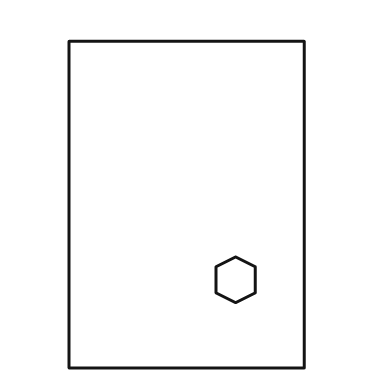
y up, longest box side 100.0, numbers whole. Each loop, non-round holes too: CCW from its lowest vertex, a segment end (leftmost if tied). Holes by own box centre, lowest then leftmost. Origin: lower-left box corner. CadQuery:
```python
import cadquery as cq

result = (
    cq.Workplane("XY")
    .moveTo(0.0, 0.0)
    .lineTo(72.0, 0.0)
    .lineTo(72.0, 100.0)
    .lineTo(0.0, 100.0)
    .close()
    .moveTo(51.0, 20.0)
    .lineTo(57.0, 23.0)
    .lineTo(57.0, 31.0)
    .lineTo(51.0, 34.0)
    .lineTo(45.0, 31.0)
    .lineTo(45.0, 23.0)
    .close()
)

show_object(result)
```